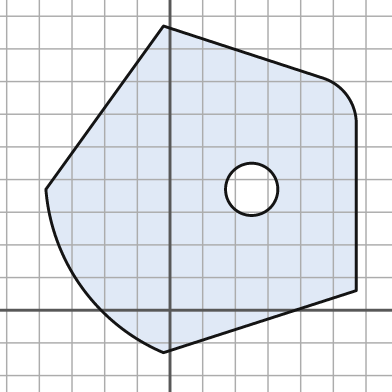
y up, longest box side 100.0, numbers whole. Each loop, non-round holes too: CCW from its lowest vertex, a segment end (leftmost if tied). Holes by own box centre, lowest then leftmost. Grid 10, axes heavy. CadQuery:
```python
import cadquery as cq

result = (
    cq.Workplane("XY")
    .moveTo(-2.0, -13.0)
    .lineTo(57.0, 6.0)
    .lineTo(57.0, 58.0)
    .threePointArc((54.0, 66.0), (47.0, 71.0))
    .lineTo(-2.0, 87.0)
    .lineTo(-38.0, 37.0)
    .threePointArc((-27.0, 7.0), (-2.0, -13.0))
    .close()
    .moveTo(25.0, 37.0)
    .circle(8.0)
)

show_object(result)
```